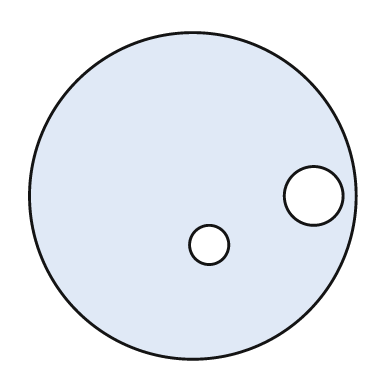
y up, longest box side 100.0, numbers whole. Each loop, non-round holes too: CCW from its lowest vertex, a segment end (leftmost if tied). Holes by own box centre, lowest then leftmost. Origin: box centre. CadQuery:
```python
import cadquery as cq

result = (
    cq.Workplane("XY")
    .moveTo(0.0, 0.0)
    .circle(50.0)
    .moveTo(5.0, -15.0)
    .circle(6.0)
    .moveTo(37.0, 0.0)
    .circle(9.0)
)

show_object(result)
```